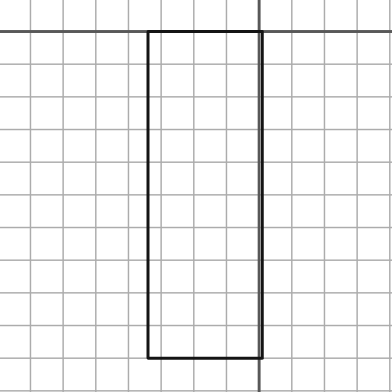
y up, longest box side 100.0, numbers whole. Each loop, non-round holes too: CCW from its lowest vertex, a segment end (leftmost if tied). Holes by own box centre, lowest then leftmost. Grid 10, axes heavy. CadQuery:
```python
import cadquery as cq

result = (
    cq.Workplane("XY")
    .moveTo(-34.0, -100.0)
    .lineTo(1.0, -100.0)
    .lineTo(1.0, 0.0)
    .lineTo(-34.0, 0.0)
    .close()
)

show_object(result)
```